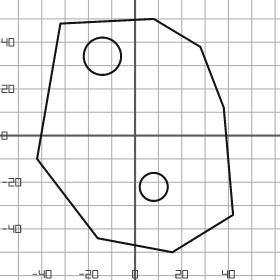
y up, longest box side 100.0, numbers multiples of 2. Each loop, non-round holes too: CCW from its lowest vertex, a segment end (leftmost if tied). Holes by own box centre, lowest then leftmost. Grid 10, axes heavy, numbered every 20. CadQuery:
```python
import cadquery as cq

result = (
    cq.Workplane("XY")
    .moveTo(16.0, -50.0)
    .lineTo(42.0, -34.0)
    .lineTo(38.0, 12.0)
    .lineTo(28.0, 38.0)
    .lineTo(8.0, 50.0)
    .lineTo(-32.0, 48.0)
    .lineTo(-42.0, -10.0)
    .lineTo(-16.0, -44.0)
    .close()
    .moveTo(8.0, -22.0)
    .circle(6.0)
    .moveTo(-14.0, 34.0)
    .circle(8.0)
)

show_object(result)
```